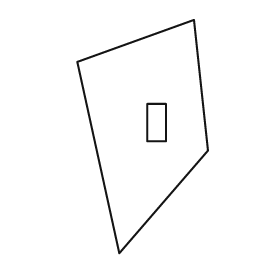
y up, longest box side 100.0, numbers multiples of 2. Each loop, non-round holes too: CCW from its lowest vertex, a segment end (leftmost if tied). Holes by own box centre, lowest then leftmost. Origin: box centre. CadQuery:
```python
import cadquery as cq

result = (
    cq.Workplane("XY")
    .moveTo(-10.0, -50.0)
    .lineTo(28.0, -6.0)
    .lineTo(22.0, 50.0)
    .lineTo(-28.0, 32.0)
    .close()
    .moveTo(2.0, -2.0)
    .lineTo(10.0, -2.0)
    .lineTo(10.0, 14.0)
    .lineTo(2.0, 14.0)
    .close()
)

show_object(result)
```